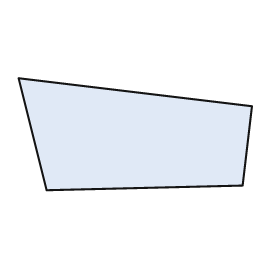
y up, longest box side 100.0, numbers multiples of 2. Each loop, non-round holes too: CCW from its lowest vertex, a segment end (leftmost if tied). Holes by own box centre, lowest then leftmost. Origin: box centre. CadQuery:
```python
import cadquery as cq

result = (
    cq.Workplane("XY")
    .moveTo(-38.0, -24.0)
    .lineTo(46.0, -22.0)
    .lineTo(50.0, 12.0)
    .lineTo(-50.0, 24.0)
    .close()
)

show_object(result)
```